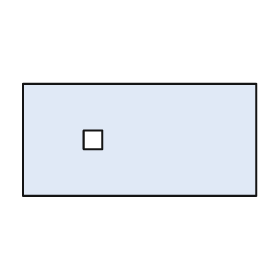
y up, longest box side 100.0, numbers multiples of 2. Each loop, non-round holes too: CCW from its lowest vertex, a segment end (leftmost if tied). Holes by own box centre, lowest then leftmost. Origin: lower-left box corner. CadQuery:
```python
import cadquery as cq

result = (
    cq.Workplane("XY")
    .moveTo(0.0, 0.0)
    .lineTo(100.0, 0.0)
    .lineTo(100.0, 48.0)
    .lineTo(0.0, 48.0)
    .close()
    .moveTo(26.0, 20.0)
    .lineTo(34.0, 20.0)
    .lineTo(34.0, 28.0)
    .lineTo(26.0, 28.0)
    .close()
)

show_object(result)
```